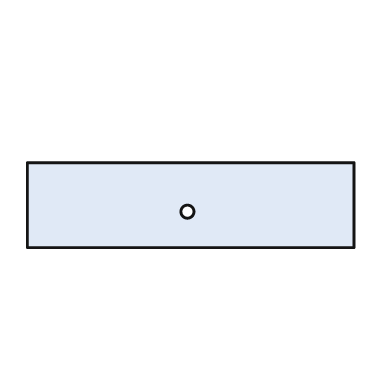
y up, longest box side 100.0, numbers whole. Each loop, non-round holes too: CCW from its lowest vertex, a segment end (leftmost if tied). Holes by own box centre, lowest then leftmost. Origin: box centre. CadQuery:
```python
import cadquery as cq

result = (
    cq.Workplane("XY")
    .moveTo(-50.0, -13.0)
    .lineTo(50.0, -13.0)
    .lineTo(50.0, 13.0)
    .lineTo(-50.0, 13.0)
    .close()
    .moveTo(-1.0, -2.0)
    .circle(2.0)
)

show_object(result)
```